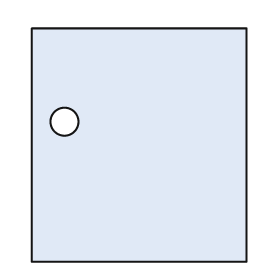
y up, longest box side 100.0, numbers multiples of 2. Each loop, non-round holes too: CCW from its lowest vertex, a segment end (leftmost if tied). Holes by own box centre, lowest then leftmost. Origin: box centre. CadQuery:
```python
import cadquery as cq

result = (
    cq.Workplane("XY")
    .moveTo(-46.0, -50.0)
    .lineTo(46.0, -50.0)
    .lineTo(46.0, 50.0)
    .lineTo(-46.0, 50.0)
    .close()
    .moveTo(-32.0, 10.0)
    .circle(6.0)
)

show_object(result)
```